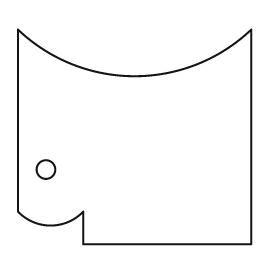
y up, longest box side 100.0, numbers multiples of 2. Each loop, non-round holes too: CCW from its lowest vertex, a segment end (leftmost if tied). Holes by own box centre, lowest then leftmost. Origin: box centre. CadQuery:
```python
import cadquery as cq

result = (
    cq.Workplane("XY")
    .moveTo(-22.0, -46.0)
    .lineTo(50.0, -46.0)
    .lineTo(50.0, 46.0)
    .threePointArc((0.0, 26.0), (-50.0, 46.0))
    .lineTo(-50.0, -32.0)
    .threePointArc((-36.0, -38.0), (-22.0, -32.0))
    .close()
    .moveTo(-38.0, -14.0)
    .circle(4.0)
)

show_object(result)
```